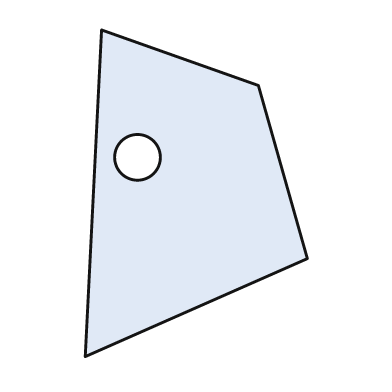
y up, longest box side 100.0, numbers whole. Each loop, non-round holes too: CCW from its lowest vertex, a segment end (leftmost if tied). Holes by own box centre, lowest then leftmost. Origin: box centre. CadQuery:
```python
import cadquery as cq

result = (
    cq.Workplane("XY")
    .moveTo(-34.0, -50.0)
    .lineTo(34.0, -20.0)
    .lineTo(19.0, 33.0)
    .lineTo(-29.0, 50.0)
    .close()
    .moveTo(-18.0, 11.0)
    .circle(7.0)
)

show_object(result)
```